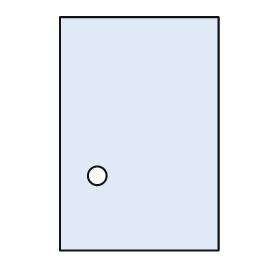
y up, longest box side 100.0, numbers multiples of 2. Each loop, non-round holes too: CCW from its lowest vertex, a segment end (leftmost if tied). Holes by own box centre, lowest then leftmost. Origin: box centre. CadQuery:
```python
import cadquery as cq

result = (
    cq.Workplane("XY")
    .moveTo(-34.0, -50.0)
    .lineTo(34.0, -50.0)
    .lineTo(34.0, 50.0)
    .lineTo(-34.0, 50.0)
    .close()
    .moveTo(-18.0, -18.0)
    .circle(4.0)
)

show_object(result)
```